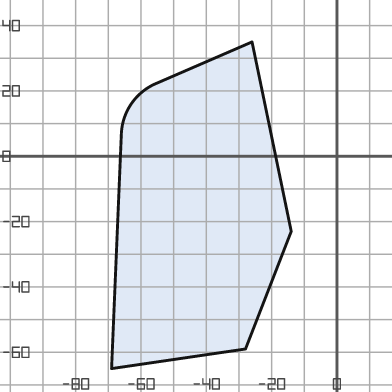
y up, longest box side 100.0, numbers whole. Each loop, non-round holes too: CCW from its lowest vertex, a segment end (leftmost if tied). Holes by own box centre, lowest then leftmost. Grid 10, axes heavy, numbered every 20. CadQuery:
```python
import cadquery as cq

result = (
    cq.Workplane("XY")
    .moveTo(-69.0, -65.0)
    .lineTo(-28.0, -59.0)
    .lineTo(-14.0, -23.0)
    .lineTo(-26.0, 35.0)
    .lineTo(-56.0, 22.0)
    .threePointArc((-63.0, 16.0), (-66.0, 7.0))
    .close()
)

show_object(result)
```